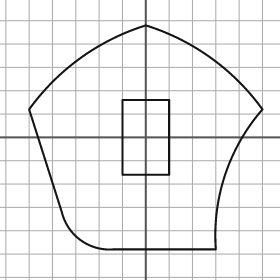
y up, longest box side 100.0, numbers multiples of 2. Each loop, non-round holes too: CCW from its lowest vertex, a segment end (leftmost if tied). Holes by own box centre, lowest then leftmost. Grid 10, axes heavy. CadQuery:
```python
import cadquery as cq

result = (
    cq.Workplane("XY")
    .moveTo(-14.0, -48.0)
    .lineTo(30.0, -48.0)
    .threePointArc((34.0, -16.0), (50.0, 12.0))
    .threePointArc((28.0, 34.0), (0.0, 48.0))
    .threePointArc((-28.0, 34.0), (-50.0, 12.0))
    .lineTo(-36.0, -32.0)
    .threePointArc((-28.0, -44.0), (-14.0, -48.0))
    .close()
    .moveTo(-10.0, -16.0)
    .lineTo(10.0, -16.0)
    .lineTo(10.0, 16.0)
    .lineTo(-10.0, 16.0)
    .close()
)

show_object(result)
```